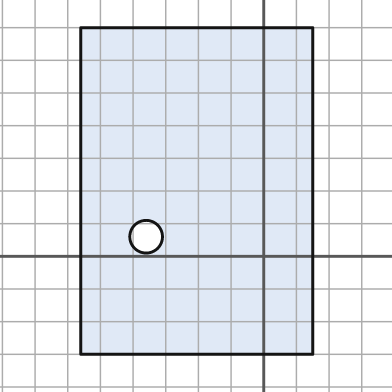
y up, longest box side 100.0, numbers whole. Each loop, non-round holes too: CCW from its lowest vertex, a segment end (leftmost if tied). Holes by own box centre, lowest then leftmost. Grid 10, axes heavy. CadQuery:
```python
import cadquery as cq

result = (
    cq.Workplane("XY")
    .moveTo(-56.0, -30.0)
    .lineTo(15.0, -30.0)
    .lineTo(15.0, 70.0)
    .lineTo(-56.0, 70.0)
    .close()
    .moveTo(-36.0, 6.0)
    .circle(5.0)
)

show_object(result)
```